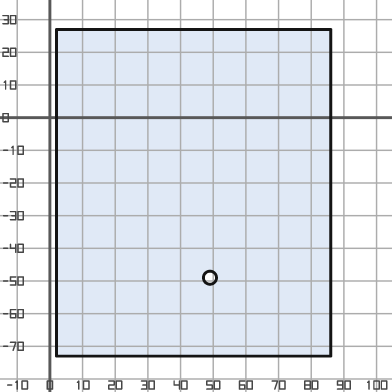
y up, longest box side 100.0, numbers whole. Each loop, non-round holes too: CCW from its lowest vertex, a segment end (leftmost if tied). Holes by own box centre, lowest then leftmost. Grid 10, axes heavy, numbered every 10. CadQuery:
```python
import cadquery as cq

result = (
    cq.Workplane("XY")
    .moveTo(2.0, -73.0)
    .lineTo(86.0, -73.0)
    .lineTo(86.0, 27.0)
    .lineTo(2.0, 27.0)
    .close()
    .moveTo(49.0, -49.0)
    .circle(2.0)
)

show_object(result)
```